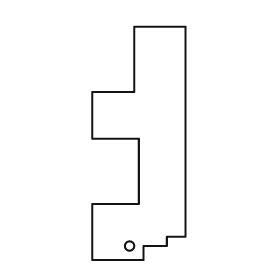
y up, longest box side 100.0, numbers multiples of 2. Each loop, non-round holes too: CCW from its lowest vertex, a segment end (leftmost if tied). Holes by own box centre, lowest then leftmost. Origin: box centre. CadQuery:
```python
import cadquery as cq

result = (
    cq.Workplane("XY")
    .moveTo(-20.0, -50.0)
    .lineTo(2.0, -50.0)
    .lineTo(2.0, -44.0)
    .lineTo(12.0, -44.0)
    .lineTo(12.0, -40.0)
    .lineTo(20.0, -40.0)
    .lineTo(20.0, 50.0)
    .lineTo(-2.0, 50.0)
    .lineTo(-2.0, 22.0)
    .lineTo(-20.0, 22.0)
    .lineTo(-20.0, 2.0)
    .lineTo(0.0, 2.0)
    .lineTo(0.0, -26.0)
    .lineTo(-20.0, -26.0)
    .close()
    .moveTo(-4.0, -44.0)
    .circle(2.0)
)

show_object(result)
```